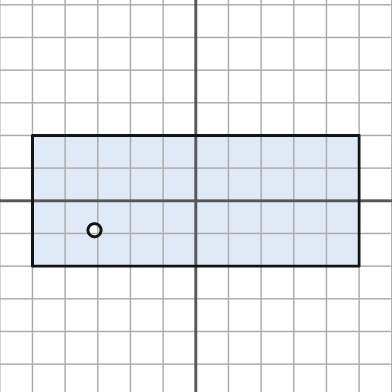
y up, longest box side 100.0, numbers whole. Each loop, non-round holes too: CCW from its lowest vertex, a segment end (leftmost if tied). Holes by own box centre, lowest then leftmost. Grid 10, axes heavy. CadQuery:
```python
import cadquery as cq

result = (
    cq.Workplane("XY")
    .moveTo(-50.0, -20.0)
    .lineTo(50.0, -20.0)
    .lineTo(50.0, 20.0)
    .lineTo(-50.0, 20.0)
    .close()
    .moveTo(-31.0, -9.0)
    .circle(2.0)
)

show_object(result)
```